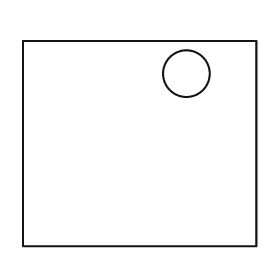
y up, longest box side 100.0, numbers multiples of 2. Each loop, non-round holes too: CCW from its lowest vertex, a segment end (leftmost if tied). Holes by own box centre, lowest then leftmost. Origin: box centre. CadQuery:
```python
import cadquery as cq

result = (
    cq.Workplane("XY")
    .moveTo(-50.0, -44.0)
    .lineTo(50.0, -44.0)
    .lineTo(50.0, 44.0)
    .lineTo(-50.0, 44.0)
    .close()
    .moveTo(20.0, 30.0)
    .circle(10.0)
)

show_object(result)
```